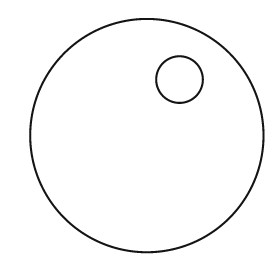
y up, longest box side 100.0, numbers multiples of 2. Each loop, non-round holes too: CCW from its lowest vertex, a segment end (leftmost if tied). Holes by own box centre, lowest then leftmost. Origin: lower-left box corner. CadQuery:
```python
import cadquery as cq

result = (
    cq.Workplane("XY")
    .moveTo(50.0, 50.0)
    .circle(50.0)
    .moveTo(64.0, 74.0)
    .circle(10.0)
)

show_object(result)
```